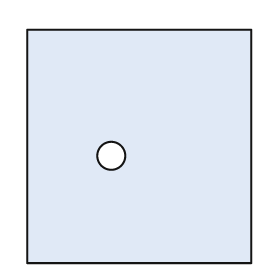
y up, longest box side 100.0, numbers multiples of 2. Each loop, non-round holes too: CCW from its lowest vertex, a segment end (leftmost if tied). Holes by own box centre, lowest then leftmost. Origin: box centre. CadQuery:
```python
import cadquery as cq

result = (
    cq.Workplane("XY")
    .moveTo(-48.0, -50.0)
    .lineTo(48.0, -50.0)
    .lineTo(48.0, 50.0)
    .lineTo(-48.0, 50.0)
    .close()
    .moveTo(-12.0, -4.0)
    .circle(6.0)
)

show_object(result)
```